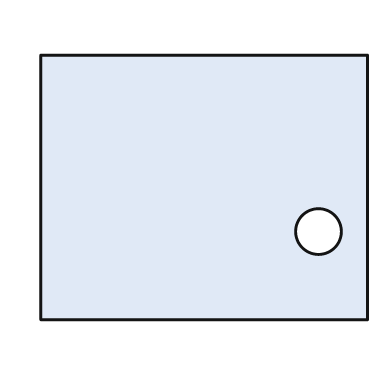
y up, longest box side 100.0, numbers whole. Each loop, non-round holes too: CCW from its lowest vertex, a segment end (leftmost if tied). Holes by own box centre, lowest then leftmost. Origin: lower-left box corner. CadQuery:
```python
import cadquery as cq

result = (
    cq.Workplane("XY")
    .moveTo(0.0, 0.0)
    .lineTo(100.0, 0.0)
    .lineTo(100.0, 81.0)
    .lineTo(0.0, 81.0)
    .close()
    .moveTo(85.0, 27.0)
    .circle(7.0)
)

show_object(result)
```